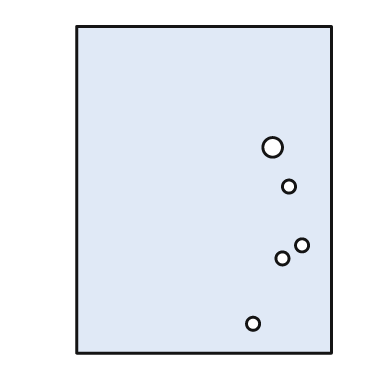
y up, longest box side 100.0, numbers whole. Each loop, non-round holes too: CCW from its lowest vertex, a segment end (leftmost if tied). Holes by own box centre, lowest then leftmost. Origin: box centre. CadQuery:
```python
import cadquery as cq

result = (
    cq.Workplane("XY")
    .moveTo(-39.0, -50.0)
    .lineTo(39.0, -50.0)
    .lineTo(39.0, 50.0)
    .lineTo(-39.0, 50.0)
    .close()
    .moveTo(15.0, -41.0)
    .circle(2.0)
    .moveTo(24.0, -21.0)
    .circle(2.0)
    .moveTo(30.0, -17.0)
    .circle(2.0)
    .moveTo(26.0, 1.0)
    .circle(2.0)
    .moveTo(21.0, 13.0)
    .circle(3.0)
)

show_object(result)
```